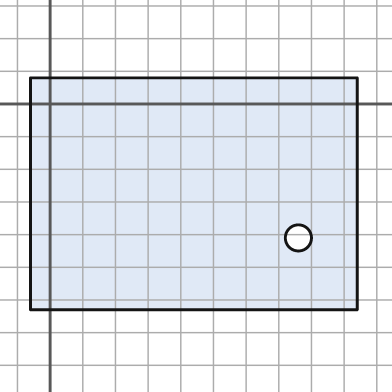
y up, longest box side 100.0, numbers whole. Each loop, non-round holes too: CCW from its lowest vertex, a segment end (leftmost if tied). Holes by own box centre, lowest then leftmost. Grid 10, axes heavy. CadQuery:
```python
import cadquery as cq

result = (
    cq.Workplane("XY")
    .moveTo(-6.0, -63.0)
    .lineTo(94.0, -63.0)
    .lineTo(94.0, 8.0)
    .lineTo(-6.0, 8.0)
    .close()
    .moveTo(76.0, -41.0)
    .circle(4.0)
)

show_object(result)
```